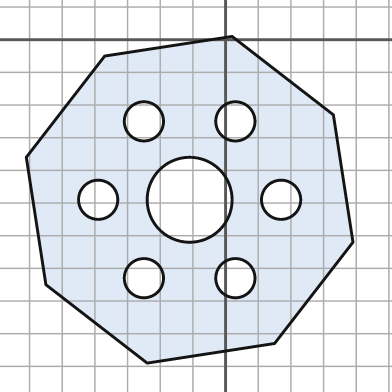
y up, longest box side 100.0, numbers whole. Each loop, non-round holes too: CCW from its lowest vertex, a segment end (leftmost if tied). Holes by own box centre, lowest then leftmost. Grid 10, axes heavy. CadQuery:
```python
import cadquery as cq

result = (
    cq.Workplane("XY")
    .moveTo(-24.0, -99.0)
    .lineTo(15.0, -93.0)
    .lineTo(39.0, -62.0)
    .lineTo(33.0, -23.0)
    .lineTo(2.0, 1.0)
    .lineTo(-37.0, -5.0)
    .lineTo(-61.0, -36.0)
    .lineTo(-55.0, -75.0)
    .close()
    .moveTo(-25.0, -73.0)
    .circle(6.0)
    .moveTo(3.0, -73.0)
    .circle(6.0)
    .moveTo(-39.0, -49.0)
    .circle(6.0)
    .moveTo(-11.0, -49.0)
    .circle(13.0)
    .moveTo(17.0, -49.0)
    .circle(6.0)
    .moveTo(-25.0, -25.0)
    .circle(6.0)
    .moveTo(3.0, -25.0)
    .circle(6.0)
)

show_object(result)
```